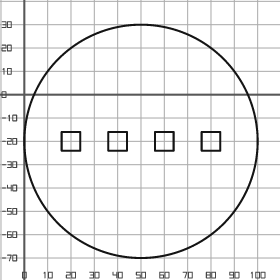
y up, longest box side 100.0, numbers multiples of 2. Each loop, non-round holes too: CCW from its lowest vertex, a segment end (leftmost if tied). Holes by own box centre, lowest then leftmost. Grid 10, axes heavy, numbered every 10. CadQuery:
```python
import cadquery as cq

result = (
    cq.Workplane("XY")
    .moveTo(50.0, -20.0)
    .circle(50.0)
    .moveTo(16.0, -24.0)
    .lineTo(24.0, -24.0)
    .lineTo(24.0, -16.0)
    .lineTo(16.0, -16.0)
    .close()
    .moveTo(36.0, -24.0)
    .lineTo(44.0, -24.0)
    .lineTo(44.0, -16.0)
    .lineTo(36.0, -16.0)
    .close()
    .moveTo(56.0, -24.0)
    .lineTo(64.0, -24.0)
    .lineTo(64.0, -16.0)
    .lineTo(56.0, -16.0)
    .close()
    .moveTo(76.0, -24.0)
    .lineTo(84.0, -24.0)
    .lineTo(84.0, -16.0)
    .lineTo(76.0, -16.0)
    .close()
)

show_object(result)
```